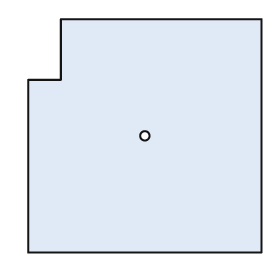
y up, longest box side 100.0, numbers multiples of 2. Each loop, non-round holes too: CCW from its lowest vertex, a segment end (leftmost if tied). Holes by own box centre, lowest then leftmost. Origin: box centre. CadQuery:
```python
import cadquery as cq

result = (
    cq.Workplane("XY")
    .moveTo(-50.0, -50.0)
    .lineTo(50.0, -50.0)
    .lineTo(50.0, 50.0)
    .lineTo(-36.0, 50.0)
    .lineTo(-36.0, 24.0)
    .lineTo(-50.0, 24.0)
    .close()
    .moveTo(0.0, 0.0)
    .circle(2.0)
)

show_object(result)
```